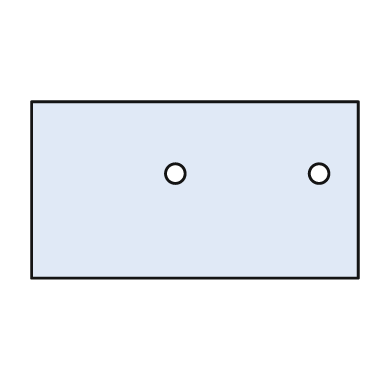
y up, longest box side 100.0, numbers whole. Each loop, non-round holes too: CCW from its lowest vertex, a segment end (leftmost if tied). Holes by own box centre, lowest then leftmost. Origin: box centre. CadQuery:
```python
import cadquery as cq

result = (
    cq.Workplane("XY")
    .moveTo(-50.0, -27.0)
    .lineTo(50.0, -27.0)
    .lineTo(50.0, 27.0)
    .lineTo(-50.0, 27.0)
    .close()
    .moveTo(-6.0, 5.0)
    .circle(3.0)
    .moveTo(38.0, 5.0)
    .circle(3.0)
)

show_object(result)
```